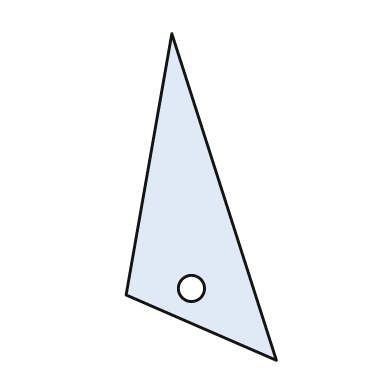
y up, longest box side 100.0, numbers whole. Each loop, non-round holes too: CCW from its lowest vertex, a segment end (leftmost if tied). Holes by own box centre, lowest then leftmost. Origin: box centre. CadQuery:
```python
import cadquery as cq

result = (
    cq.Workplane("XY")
    .moveTo(23.0, -50.0)
    .lineTo(-9.0, 50.0)
    .lineTo(-23.0, -30.0)
    .close()
    .moveTo(-3.0, -28.0)
    .circle(4.0)
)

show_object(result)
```